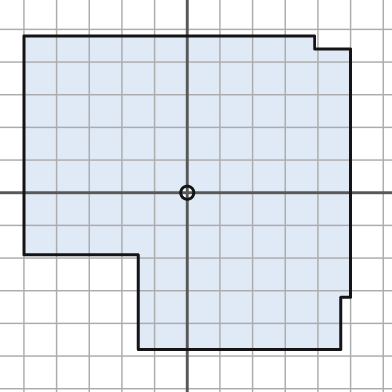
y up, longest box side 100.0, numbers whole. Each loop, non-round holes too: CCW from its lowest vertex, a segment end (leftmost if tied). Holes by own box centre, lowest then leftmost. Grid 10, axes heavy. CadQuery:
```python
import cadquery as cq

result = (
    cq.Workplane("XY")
    .moveTo(-15.0, -48.0)
    .lineTo(47.0, -48.0)
    .lineTo(47.0, -32.0)
    .lineTo(50.0, -32.0)
    .lineTo(50.0, 44.0)
    .lineTo(39.0, 44.0)
    .lineTo(39.0, 48.0)
    .lineTo(-50.0, 48.0)
    .lineTo(-50.0, -19.0)
    .lineTo(-15.0, -19.0)
    .close()
    .moveTo(0.0, 0.0)
    .circle(2.0)
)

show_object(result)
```